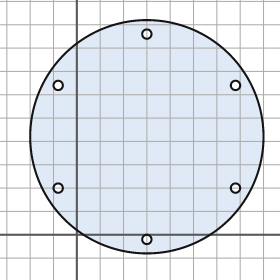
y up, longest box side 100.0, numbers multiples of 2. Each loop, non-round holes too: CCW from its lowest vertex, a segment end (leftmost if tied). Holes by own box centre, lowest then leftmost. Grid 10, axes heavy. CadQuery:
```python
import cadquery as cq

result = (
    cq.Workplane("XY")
    .moveTo(30.0, 42.0)
    .circle(50.0)
    .moveTo(30.0, -2.0)
    .circle(2.0)
    .moveTo(-8.0, 20.0)
    .circle(2.0)
    .moveTo(68.0, 20.0)
    .circle(2.0)
    .moveTo(-8.0, 64.0)
    .circle(2.0)
    .moveTo(68.0, 64.0)
    .circle(2.0)
    .moveTo(30.0, 86.0)
    .circle(2.0)
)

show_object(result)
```